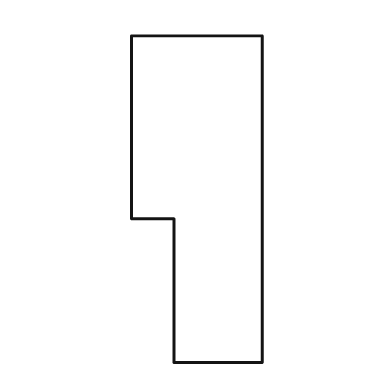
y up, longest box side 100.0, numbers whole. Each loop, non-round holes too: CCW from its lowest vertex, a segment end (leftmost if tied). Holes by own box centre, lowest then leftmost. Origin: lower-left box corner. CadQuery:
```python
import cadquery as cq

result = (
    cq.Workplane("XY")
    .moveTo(13.0, 0.0)
    .lineTo(40.0, 0.0)
    .lineTo(40.0, 100.0)
    .lineTo(0.0, 100.0)
    .lineTo(0.0, 44.0)
    .lineTo(13.0, 44.0)
    .close()
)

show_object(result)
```